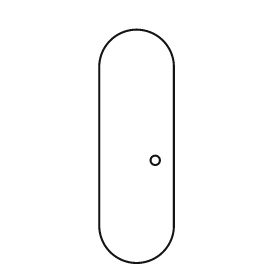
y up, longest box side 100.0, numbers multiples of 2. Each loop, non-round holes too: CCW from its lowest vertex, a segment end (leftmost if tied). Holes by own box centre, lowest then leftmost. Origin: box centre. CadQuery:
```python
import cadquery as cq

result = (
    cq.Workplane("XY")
    .moveTo(-16.0, -34.0)
    .threePointArc((0.0, -50.0), (16.0, -34.0))
    .lineTo(16.0, 34.0)
    .threePointArc((0.0, 50.0), (-16.0, 34.0))
    .close()
    .moveTo(8.0, -6.0)
    .circle(2.0)
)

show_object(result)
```